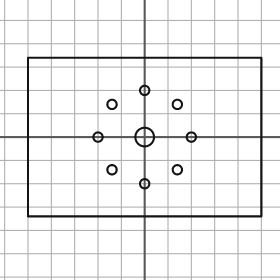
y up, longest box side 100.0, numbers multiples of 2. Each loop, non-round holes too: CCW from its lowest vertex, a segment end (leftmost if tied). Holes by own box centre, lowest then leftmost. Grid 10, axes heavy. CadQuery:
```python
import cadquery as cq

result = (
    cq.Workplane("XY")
    .moveTo(-50.0, -34.0)
    .lineTo(50.0, -34.0)
    .lineTo(50.0, 34.0)
    .lineTo(-50.0, 34.0)
    .close()
    .moveTo(0.0, -20.0)
    .circle(2.0)
    .moveTo(-14.0, -14.0)
    .circle(2.0)
    .moveTo(14.0, -14.0)
    .circle(2.0)
    .moveTo(-20.0, 0.0)
    .circle(2.0)
    .moveTo(0.0, 0.0)
    .circle(4.0)
    .moveTo(20.0, 0.0)
    .circle(2.0)
    .moveTo(-14.0, 14.0)
    .circle(2.0)
    .moveTo(14.0, 14.0)
    .circle(2.0)
    .moveTo(0.0, 20.0)
    .circle(2.0)
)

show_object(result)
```